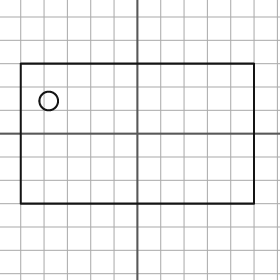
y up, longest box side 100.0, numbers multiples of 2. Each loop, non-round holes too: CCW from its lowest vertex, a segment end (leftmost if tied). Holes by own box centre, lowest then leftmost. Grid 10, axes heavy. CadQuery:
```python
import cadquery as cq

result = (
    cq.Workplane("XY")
    .moveTo(-50.0, -30.0)
    .lineTo(50.0, -30.0)
    .lineTo(50.0, 30.0)
    .lineTo(-50.0, 30.0)
    .close()
    .moveTo(-38.0, 14.0)
    .circle(4.0)
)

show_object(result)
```